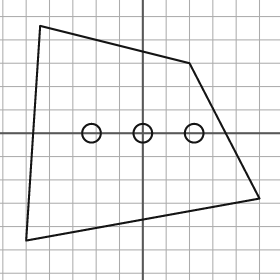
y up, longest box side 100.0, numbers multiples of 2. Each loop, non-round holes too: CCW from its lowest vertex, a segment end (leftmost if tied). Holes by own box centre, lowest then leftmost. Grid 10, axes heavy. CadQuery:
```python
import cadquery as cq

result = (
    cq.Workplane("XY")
    .moveTo(-50.0, -46.0)
    .lineTo(50.0, -28.0)
    .lineTo(20.0, 30.0)
    .lineTo(-44.0, 46.0)
    .close()
    .moveTo(-22.0, 0.0)
    .circle(4.0)
    .moveTo(0.0, 0.0)
    .circle(4.0)
    .moveTo(22.0, 0.0)
    .circle(4.0)
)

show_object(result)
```